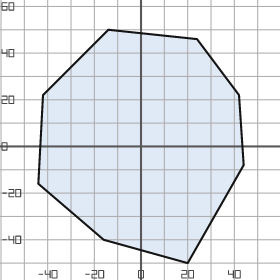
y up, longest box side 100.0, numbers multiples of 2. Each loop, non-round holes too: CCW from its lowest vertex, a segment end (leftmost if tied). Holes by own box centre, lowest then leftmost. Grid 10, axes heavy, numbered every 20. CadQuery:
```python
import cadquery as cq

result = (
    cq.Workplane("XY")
    .moveTo(20.0, -50.0)
    .lineTo(44.0, -8.0)
    .lineTo(42.0, 22.0)
    .lineTo(24.0, 46.0)
    .lineTo(-14.0, 50.0)
    .lineTo(-42.0, 22.0)
    .lineTo(-44.0, -16.0)
    .lineTo(-16.0, -40.0)
    .close()
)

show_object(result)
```